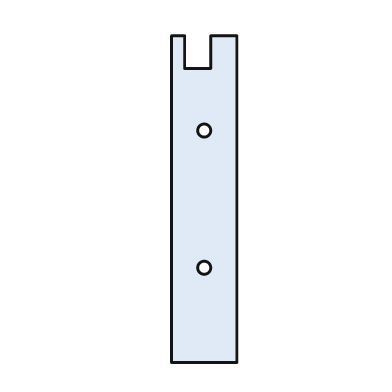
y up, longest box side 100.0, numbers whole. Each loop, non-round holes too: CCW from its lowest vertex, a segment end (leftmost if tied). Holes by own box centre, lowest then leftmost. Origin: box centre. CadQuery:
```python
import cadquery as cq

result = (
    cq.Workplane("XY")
    .moveTo(-10.0, -50.0)
    .lineTo(10.0, -50.0)
    .lineTo(10.0, 50.0)
    .lineTo(2.0, 50.0)
    .lineTo(2.0, 40.0)
    .lineTo(-6.0, 40.0)
    .lineTo(-6.0, 50.0)
    .lineTo(-10.0, 50.0)
    .close()
    .moveTo(0.0, -21.0)
    .circle(2.0)
    .moveTo(0.0, 21.0)
    .circle(2.0)
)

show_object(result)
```